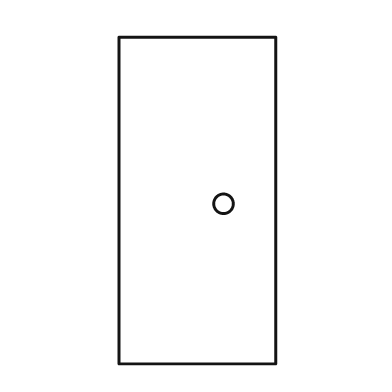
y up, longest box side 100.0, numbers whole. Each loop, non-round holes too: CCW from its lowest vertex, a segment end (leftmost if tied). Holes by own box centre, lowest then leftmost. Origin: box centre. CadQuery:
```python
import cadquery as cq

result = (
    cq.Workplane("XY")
    .moveTo(-24.0, -50.0)
    .lineTo(24.0, -50.0)
    .lineTo(24.0, 50.0)
    .lineTo(-24.0, 50.0)
    .close()
    .moveTo(8.0, -1.0)
    .circle(3.0)
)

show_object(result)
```